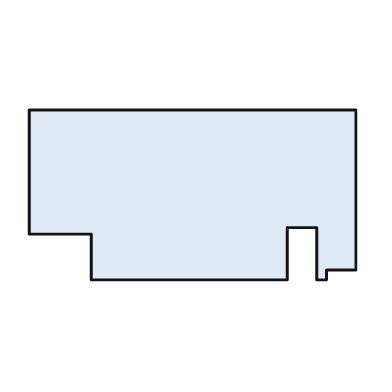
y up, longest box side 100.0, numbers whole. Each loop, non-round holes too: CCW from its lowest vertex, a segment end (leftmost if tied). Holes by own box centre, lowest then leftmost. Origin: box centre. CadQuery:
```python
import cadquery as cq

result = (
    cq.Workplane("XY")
    .moveTo(-31.0, -26.0)
    .lineTo(29.0, -26.0)
    .lineTo(29.0, -10.0)
    .lineTo(38.0, -10.0)
    .lineTo(38.0, -26.0)
    .lineTo(41.0, -26.0)
    .lineTo(41.0, -23.0)
    .lineTo(50.0, -23.0)
    .lineTo(50.0, 26.0)
    .lineTo(-50.0, 26.0)
    .lineTo(-50.0, -12.0)
    .lineTo(-31.0, -12.0)
    .close()
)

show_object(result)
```